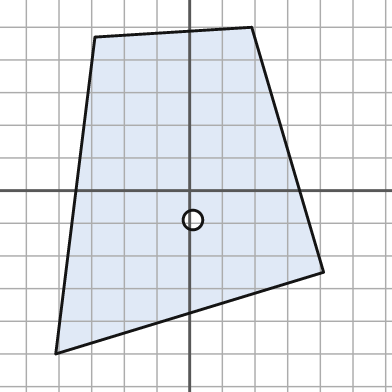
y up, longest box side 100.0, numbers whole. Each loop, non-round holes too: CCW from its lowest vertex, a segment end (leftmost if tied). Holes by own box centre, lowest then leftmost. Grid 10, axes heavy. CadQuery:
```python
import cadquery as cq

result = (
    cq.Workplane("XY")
    .moveTo(-41.0, -50.0)
    .lineTo(41.0, -25.0)
    .lineTo(19.0, 50.0)
    .lineTo(-29.0, 47.0)
    .close()
    .moveTo(1.0, -9.0)
    .circle(3.0)
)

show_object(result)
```